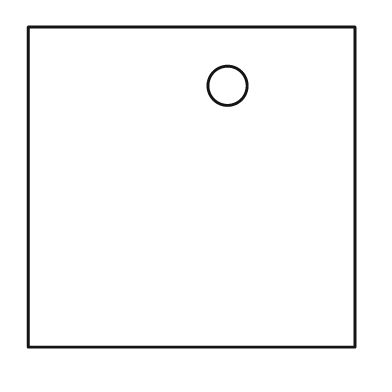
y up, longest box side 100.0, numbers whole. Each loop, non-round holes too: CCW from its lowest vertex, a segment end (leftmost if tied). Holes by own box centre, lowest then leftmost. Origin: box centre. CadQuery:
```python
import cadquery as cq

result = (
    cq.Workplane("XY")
    .moveTo(-50.0, -49.0)
    .lineTo(50.0, -49.0)
    .lineTo(50.0, 49.0)
    .lineTo(-50.0, 49.0)
    .close()
    .moveTo(11.0, 31.0)
    .circle(6.0)
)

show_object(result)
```